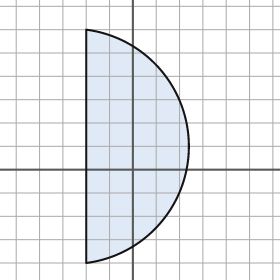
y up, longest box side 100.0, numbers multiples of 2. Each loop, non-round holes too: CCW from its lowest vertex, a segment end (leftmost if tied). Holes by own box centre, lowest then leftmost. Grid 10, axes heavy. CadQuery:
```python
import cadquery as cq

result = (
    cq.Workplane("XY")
    .moveTo(-20.0, -40.0)
    .threePointArc((24.0, 10.0), (-20.0, 60.0))
    .close()
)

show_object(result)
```